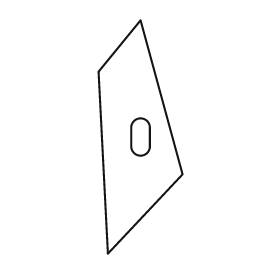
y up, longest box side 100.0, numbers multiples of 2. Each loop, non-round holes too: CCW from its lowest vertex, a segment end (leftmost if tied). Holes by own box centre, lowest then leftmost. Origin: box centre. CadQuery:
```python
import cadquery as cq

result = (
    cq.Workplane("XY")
    .moveTo(-14.0, -50.0)
    .lineTo(18.0, -16.0)
    .lineTo(0.0, 50.0)
    .lineTo(-18.0, 28.0)
    .close()
    .moveTo(-4.0, -4.0)
    .threePointArc((0.0, -8.0), (4.0, -4.0))
    .lineTo(4.0, 4.0)
    .threePointArc((0.0, 8.0), (-4.0, 4.0))
    .close()
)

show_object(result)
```